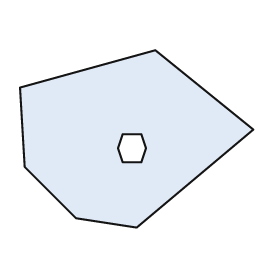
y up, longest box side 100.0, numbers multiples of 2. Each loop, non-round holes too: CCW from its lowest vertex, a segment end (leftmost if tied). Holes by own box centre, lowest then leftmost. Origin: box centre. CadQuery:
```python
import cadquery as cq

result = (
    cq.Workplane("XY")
    .moveTo(0.0, -38.0)
    .lineTo(50.0, 4.0)
    .lineTo(8.0, 38.0)
    .lineTo(-50.0, 22.0)
    .lineTo(-48.0, -12.0)
    .lineTo(-26.0, -34.0)
    .close()
    .moveTo(-6.0, -10.0)
    .lineTo(2.0, -10.0)
    .lineTo(4.0, -4.0)
    .lineTo(2.0, 2.0)
    .lineTo(-6.0, 2.0)
    .lineTo(-8.0, -4.0)
    .close()
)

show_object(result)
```